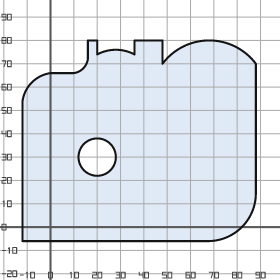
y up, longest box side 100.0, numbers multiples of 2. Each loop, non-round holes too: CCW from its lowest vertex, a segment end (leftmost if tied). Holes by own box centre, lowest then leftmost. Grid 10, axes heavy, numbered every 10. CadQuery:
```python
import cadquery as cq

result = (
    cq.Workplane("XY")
    .moveTo(-12.0, -6.0)
    .lineTo(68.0, -6.0)
    .threePointArc((82.0, 0.0), (88.0, 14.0))
    .lineTo(88.0, 70.0)
    .threePointArc((68.0, 80.0), (48.0, 70.0))
    .lineTo(48.0, 80.0)
    .lineTo(36.0, 80.0)
    .lineTo(36.0, 74.0)
    .threePointArc((28.0, 76.0), (20.0, 74.0))
    .lineTo(20.0, 80.0)
    .lineTo(16.0, 80.0)
    .lineTo(16.0, 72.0)
    .threePointArc((14.0, 68.0), (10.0, 66.0))
    .lineTo(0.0, 66.0)
    .threePointArc((-8.0, 62.0), (-12.0, 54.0))
    .close()
    .moveTo(20.0, 30.0)
    .circle(8.0)
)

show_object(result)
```